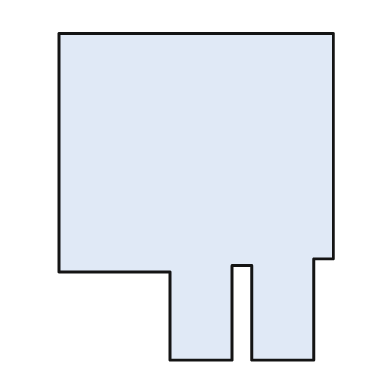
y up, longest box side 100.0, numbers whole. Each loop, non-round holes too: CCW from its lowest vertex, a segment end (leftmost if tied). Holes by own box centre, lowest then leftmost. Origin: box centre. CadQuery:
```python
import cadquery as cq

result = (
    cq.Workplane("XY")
    .moveTo(-8.0, -50.0)
    .lineTo(11.0, -50.0)
    .lineTo(11.0, -21.0)
    .lineTo(17.0, -21.0)
    .lineTo(17.0, -50.0)
    .lineTo(36.0, -50.0)
    .lineTo(36.0, -19.0)
    .lineTo(42.0, -19.0)
    .lineTo(42.0, 50.0)
    .lineTo(-42.0, 50.0)
    .lineTo(-42.0, -23.0)
    .lineTo(-8.0, -23.0)
    .close()
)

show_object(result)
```